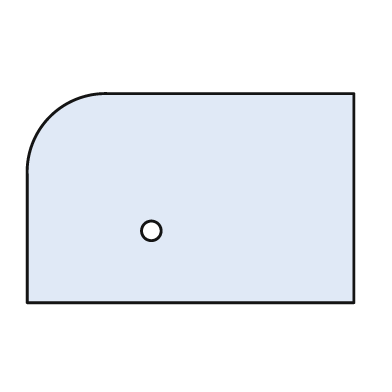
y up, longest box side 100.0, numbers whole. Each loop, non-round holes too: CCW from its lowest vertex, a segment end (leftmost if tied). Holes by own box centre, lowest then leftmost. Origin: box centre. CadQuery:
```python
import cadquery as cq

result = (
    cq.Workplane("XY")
    .moveTo(-50.0, -32.0)
    .lineTo(50.0, -32.0)
    .lineTo(50.0, 32.0)
    .lineTo(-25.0, 32.0)
    .threePointArc((-43.0, 25.0), (-50.0, 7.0))
    .close()
    .moveTo(-12.0, -10.0)
    .circle(3.0)
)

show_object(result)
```